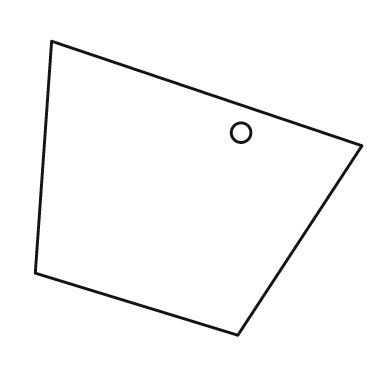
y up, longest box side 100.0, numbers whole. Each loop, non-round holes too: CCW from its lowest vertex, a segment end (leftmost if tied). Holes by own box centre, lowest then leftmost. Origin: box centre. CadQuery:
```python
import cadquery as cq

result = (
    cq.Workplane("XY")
    .moveTo(12.0, -45.0)
    .lineTo(50.0, 13.0)
    .lineTo(-45.0, 45.0)
    .lineTo(-50.0, -26.0)
    .close()
    .moveTo(13.0, 17.0)
    .circle(3.0)
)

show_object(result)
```